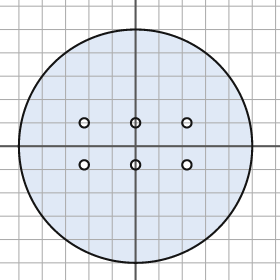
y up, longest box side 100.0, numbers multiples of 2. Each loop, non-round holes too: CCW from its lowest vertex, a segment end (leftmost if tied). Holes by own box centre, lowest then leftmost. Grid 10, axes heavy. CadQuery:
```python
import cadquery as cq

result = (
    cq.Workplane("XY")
    .moveTo(0.0, 0.0)
    .circle(50.0)
    .moveTo(-22.0, -8.0)
    .circle(2.0)
    .moveTo(0.0, -8.0)
    .circle(2.0)
    .moveTo(22.0, -8.0)
    .circle(2.0)
    .moveTo(-22.0, 10.0)
    .circle(2.0)
    .moveTo(0.0, 10.0)
    .circle(2.0)
    .moveTo(22.0, 10.0)
    .circle(2.0)
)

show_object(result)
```